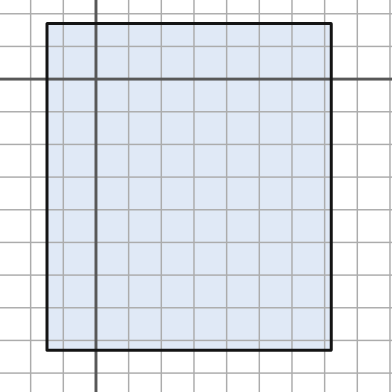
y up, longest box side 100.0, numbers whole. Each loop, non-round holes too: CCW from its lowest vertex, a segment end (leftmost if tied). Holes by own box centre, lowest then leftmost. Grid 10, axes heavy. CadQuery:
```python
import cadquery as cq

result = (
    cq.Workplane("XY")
    .moveTo(-15.0, -83.0)
    .lineTo(72.0, -83.0)
    .lineTo(72.0, 17.0)
    .lineTo(-15.0, 17.0)
    .close()
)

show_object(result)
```